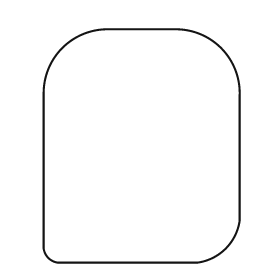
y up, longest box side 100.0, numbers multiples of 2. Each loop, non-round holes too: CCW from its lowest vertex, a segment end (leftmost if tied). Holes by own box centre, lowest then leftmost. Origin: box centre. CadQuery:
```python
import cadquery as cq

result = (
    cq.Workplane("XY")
    .moveTo(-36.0, -50.0)
    .lineTo(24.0, -50.0)
    .threePointArc((36.0, -44.0), (42.0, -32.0))
    .lineTo(42.0, 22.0)
    .threePointArc((34.0, 42.0), (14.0, 50.0))
    .lineTo(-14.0, 50.0)
    .threePointArc((-34.0, 42.0), (-42.0, 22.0))
    .lineTo(-42.0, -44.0)
    .threePointArc((-40.0, -48.0), (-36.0, -50.0))
    .close()
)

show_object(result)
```